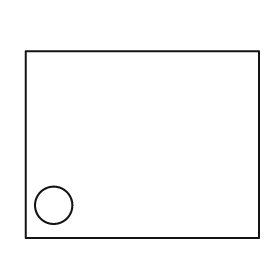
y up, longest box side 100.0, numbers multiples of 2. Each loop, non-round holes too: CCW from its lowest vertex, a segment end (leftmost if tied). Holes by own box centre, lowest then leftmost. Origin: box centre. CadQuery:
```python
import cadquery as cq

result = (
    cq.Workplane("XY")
    .moveTo(-50.0, -40.0)
    .lineTo(50.0, -40.0)
    .lineTo(50.0, 40.0)
    .lineTo(-50.0, 40.0)
    .close()
    .moveTo(-38.0, -26.0)
    .circle(8.0)
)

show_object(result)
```